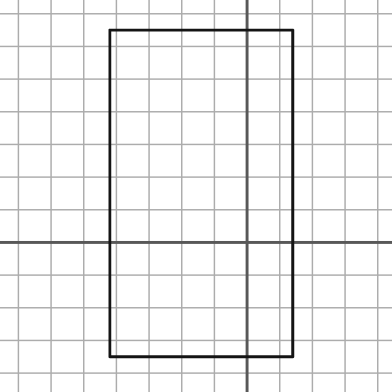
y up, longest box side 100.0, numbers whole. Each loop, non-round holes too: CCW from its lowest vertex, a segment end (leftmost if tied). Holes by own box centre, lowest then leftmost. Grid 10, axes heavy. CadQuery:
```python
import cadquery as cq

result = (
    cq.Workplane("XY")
    .moveTo(-42.0, -35.0)
    .lineTo(14.0, -35.0)
    .lineTo(14.0, 65.0)
    .lineTo(-42.0, 65.0)
    .close()
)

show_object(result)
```